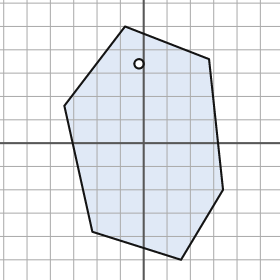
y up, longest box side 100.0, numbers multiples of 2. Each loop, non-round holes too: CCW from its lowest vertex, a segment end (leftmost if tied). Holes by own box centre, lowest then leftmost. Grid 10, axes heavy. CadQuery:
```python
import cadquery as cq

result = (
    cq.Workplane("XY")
    .moveTo(16.0, -50.0)
    .lineTo(34.0, -20.0)
    .lineTo(28.0, 36.0)
    .lineTo(-8.0, 50.0)
    .lineTo(-34.0, 16.0)
    .lineTo(-22.0, -38.0)
    .close()
    .moveTo(-2.0, 34.0)
    .circle(2.0)
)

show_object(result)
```